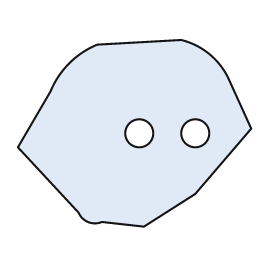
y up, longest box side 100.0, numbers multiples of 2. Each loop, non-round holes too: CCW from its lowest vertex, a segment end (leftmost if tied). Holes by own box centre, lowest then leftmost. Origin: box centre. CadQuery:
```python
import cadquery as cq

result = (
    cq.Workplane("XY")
    .moveTo(4.0, -40.0)
    .lineTo(26.0, -26.0)
    .lineTo(50.0, 2.0)
    .lineTo(40.0, 24.0)
    .threePointArc((32.0, 34.0), (20.0, 40.0))
    .lineTo(-16.0, 38.0)
    .threePointArc((-28.0, 30.0), (-36.0, 18.0))
    .lineTo(-50.0, -6.0)
    .lineTo(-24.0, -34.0)
    .threePointArc((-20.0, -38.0), (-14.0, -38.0))
    .close()
    .moveTo(2.0, 0.0)
    .circle(6.0)
    .moveTo(26.0, 0.0)
    .circle(6.0)
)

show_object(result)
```